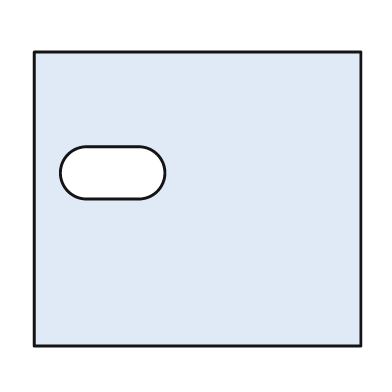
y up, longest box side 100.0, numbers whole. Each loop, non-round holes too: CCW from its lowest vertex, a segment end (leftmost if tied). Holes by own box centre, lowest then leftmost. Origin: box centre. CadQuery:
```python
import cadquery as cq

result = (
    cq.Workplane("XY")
    .moveTo(-50.0, -45.0)
    .lineTo(50.0, -45.0)
    .lineTo(50.0, 45.0)
    .lineTo(-50.0, 45.0)
    .close()
    .moveTo(-34.0, 0.0)
    .lineTo(-18.0, 0.0)
    .threePointArc((-10.0, 8.0), (-18.0, 16.0))
    .lineTo(-34.0, 16.0)
    .threePointArc((-42.0, 8.0), (-34.0, 0.0))
    .close()
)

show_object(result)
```